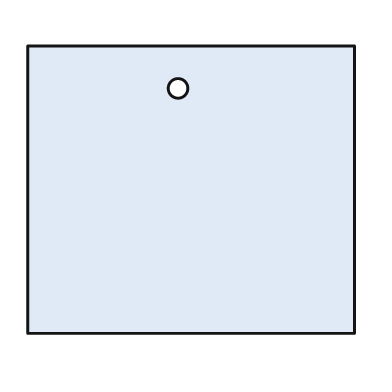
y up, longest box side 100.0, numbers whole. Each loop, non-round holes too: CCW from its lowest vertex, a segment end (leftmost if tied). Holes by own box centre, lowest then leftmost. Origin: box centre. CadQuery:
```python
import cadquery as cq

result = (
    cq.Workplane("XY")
    .moveTo(-50.0, -44.0)
    .lineTo(50.0, -44.0)
    .lineTo(50.0, 44.0)
    .lineTo(-50.0, 44.0)
    .close()
    .moveTo(-4.0, 31.0)
    .circle(3.0)
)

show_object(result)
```